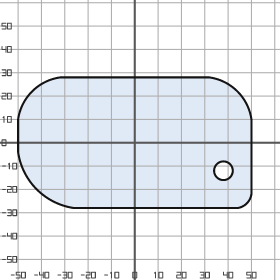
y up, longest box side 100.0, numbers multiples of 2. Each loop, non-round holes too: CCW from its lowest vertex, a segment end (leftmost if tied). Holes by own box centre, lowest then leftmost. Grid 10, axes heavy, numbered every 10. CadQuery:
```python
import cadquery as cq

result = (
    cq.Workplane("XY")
    .moveTo(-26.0, -28.0)
    .lineTo(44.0, -28.0)
    .threePointArc((48.0, -26.0), (50.0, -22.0))
    .lineTo(50.0, 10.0)
    .threePointArc((44.0, 22.0), (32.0, 28.0))
    .lineTo(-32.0, 28.0)
    .threePointArc((-44.0, 22.0), (-50.0, 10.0))
    .lineTo(-50.0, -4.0)
    .threePointArc((-42.0, -20.0), (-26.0, -28.0))
    .close()
    .moveTo(38.0, -12.0)
    .circle(4.0)
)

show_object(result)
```